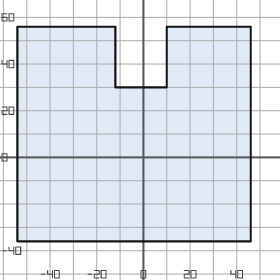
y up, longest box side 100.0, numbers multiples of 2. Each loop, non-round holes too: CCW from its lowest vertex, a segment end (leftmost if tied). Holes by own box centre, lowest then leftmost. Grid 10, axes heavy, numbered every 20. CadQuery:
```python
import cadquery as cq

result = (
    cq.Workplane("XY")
    .moveTo(-54.0, -36.0)
    .lineTo(46.0, -36.0)
    .lineTo(46.0, 56.0)
    .lineTo(10.0, 56.0)
    .lineTo(10.0, 30.0)
    .lineTo(-12.0, 30.0)
    .lineTo(-12.0, 56.0)
    .lineTo(-54.0, 56.0)
    .close()
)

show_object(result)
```